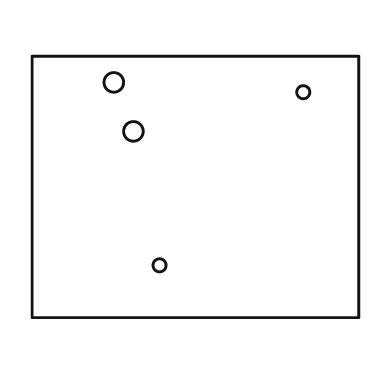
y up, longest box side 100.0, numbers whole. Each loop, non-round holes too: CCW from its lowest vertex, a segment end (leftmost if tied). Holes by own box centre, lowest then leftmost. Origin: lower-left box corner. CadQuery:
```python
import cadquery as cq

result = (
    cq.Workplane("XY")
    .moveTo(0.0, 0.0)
    .lineTo(100.0, 0.0)
    .lineTo(100.0, 80.0)
    .lineTo(0.0, 80.0)
    .close()
    .moveTo(39.0, 16.0)
    .circle(2.0)
    .moveTo(31.0, 57.0)
    .circle(3.0)
    .moveTo(83.0, 69.0)
    .circle(2.0)
    .moveTo(25.0, 72.0)
    .circle(3.0)
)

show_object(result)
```